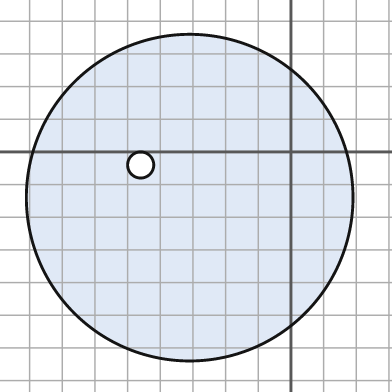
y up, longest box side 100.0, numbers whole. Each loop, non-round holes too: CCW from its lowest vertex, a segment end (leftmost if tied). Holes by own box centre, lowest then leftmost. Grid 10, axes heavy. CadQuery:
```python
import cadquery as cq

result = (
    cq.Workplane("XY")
    .moveTo(-31.0, -14.0)
    .circle(50.0)
    .moveTo(-46.0, -4.0)
    .circle(4.0)
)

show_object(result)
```